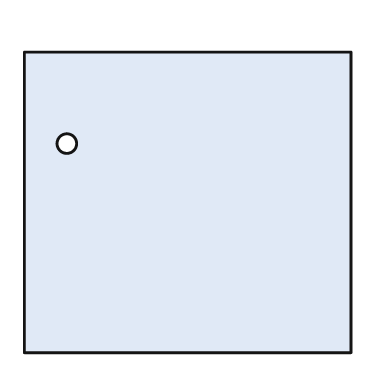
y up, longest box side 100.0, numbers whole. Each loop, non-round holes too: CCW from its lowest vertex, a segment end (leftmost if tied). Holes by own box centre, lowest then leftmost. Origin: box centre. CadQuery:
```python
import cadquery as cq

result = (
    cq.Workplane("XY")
    .moveTo(-50.0, -46.0)
    .lineTo(50.0, -46.0)
    .lineTo(50.0, 46.0)
    .lineTo(-50.0, 46.0)
    .close()
    .moveTo(-37.0, 18.0)
    .circle(3.0)
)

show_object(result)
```